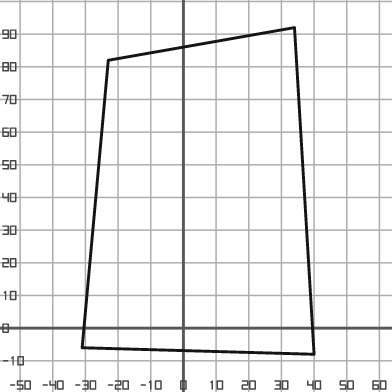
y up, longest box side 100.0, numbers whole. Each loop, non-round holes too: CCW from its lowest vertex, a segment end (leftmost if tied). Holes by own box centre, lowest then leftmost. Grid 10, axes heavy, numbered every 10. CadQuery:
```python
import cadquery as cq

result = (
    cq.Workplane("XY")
    .moveTo(40.0, -8.0)
    .lineTo(34.0, 92.0)
    .lineTo(-23.0, 82.0)
    .lineTo(-31.0, -6.0)
    .close()
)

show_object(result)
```